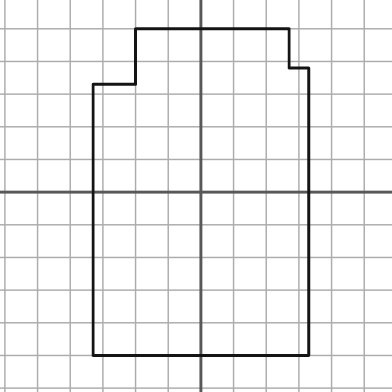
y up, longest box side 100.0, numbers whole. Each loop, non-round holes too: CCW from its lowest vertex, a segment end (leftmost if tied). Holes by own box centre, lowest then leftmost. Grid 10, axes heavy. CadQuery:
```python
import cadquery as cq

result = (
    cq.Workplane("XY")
    .moveTo(-33.0, -50.0)
    .lineTo(33.0, -50.0)
    .lineTo(33.0, 38.0)
    .lineTo(27.0, 38.0)
    .lineTo(27.0, 50.0)
    .lineTo(-20.0, 50.0)
    .lineTo(-20.0, 33.0)
    .lineTo(-33.0, 33.0)
    .close()
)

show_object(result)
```